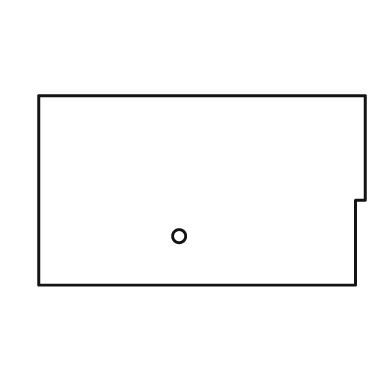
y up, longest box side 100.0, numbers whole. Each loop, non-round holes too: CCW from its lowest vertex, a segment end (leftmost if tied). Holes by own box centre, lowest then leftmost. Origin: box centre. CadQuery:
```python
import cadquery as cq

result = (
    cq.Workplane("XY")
    .moveTo(-50.0, -29.0)
    .lineTo(47.0, -29.0)
    .lineTo(47.0, -3.0)
    .lineTo(50.0, -3.0)
    .lineTo(50.0, 29.0)
    .lineTo(-50.0, 29.0)
    .close()
    .moveTo(-7.0, -14.0)
    .circle(2.0)
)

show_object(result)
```